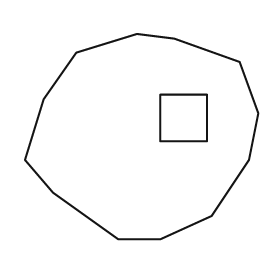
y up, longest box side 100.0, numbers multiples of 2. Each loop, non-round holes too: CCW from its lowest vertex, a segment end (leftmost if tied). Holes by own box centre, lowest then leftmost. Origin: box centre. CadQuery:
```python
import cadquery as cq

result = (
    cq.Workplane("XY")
    .moveTo(-10.0, -44.0)
    .lineTo(8.0, -44.0)
    .lineTo(30.0, -34.0)
    .lineTo(46.0, -10.0)
    .lineTo(50.0, 10.0)
    .lineTo(42.0, 32.0)
    .lineTo(14.0, 42.0)
    .lineTo(-2.0, 44.0)
    .lineTo(-28.0, 36.0)
    .lineTo(-42.0, 16.0)
    .lineTo(-50.0, -10.0)
    .lineTo(-38.0, -24.0)
    .close()
    .moveTo(8.0, -2.0)
    .lineTo(28.0, -2.0)
    .lineTo(28.0, 18.0)
    .lineTo(8.0, 18.0)
    .close()
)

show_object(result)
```